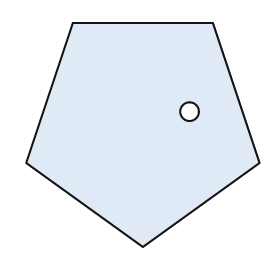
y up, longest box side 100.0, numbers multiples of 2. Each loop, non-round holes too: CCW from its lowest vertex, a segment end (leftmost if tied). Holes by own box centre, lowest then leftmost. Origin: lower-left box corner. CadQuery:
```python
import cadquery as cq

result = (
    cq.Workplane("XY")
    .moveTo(50.0, 0.0)
    .lineTo(100.0, 36.0)
    .lineTo(80.0, 96.0)
    .lineTo(20.0, 96.0)
    .lineTo(0.0, 36.0)
    .close()
    .moveTo(70.0, 58.0)
    .circle(4.0)
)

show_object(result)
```